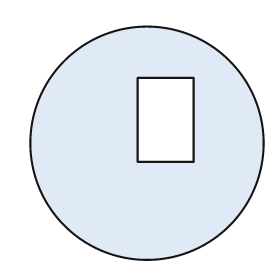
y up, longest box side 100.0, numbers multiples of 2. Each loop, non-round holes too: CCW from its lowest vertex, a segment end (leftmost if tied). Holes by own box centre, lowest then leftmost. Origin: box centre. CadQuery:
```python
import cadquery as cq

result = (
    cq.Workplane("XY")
    .moveTo(0.0, 0.0)
    .circle(50.0)
    .moveTo(-4.0, -8.0)
    .lineTo(20.0, -8.0)
    .lineTo(20.0, 28.0)
    .lineTo(-4.0, 28.0)
    .close()
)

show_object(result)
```